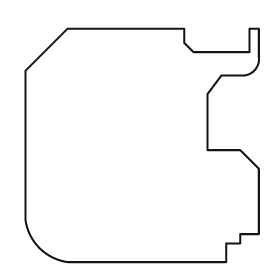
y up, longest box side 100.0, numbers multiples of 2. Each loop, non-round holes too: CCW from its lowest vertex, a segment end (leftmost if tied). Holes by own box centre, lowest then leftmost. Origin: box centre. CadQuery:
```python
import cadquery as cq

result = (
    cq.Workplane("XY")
    .moveTo(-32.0, -50.0)
    .lineTo(36.0, -50.0)
    .lineTo(36.0, -42.0)
    .lineTo(42.0, -42.0)
    .lineTo(42.0, -38.0)
    .lineTo(50.0, -38.0)
    .lineTo(50.0, -10.0)
    .lineTo(42.0, -2.0)
    .lineTo(28.0, -2.0)
    .lineTo(28.0, 22.0)
    .lineTo(34.0, 30.0)
    .lineTo(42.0, 30.0)
    .threePointArc((48.0, 32.0), (50.0, 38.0))
    .lineTo(50.0, 50.0)
    .lineTo(46.0, 50.0)
    .lineTo(46.0, 40.0)
    .lineTo(22.0, 40.0)
    .lineTo(18.0, 44.0)
    .lineTo(18.0, 50.0)
    .lineTo(-32.0, 50.0)
    .lineTo(-50.0, 32.0)
    .lineTo(-50.0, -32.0)
    .threePointArc((-44.0, -44.0), (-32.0, -50.0))
    .close()
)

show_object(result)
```